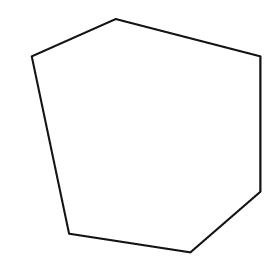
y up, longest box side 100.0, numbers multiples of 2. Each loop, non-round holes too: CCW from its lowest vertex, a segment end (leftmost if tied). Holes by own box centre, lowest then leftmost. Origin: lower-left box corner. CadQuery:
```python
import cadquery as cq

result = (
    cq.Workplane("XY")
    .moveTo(68.0, 0.0)
    .lineTo(98.0, 26.0)
    .lineTo(98.0, 84.0)
    .lineTo(36.0, 100.0)
    .lineTo(0.0, 84.0)
    .lineTo(16.0, 8.0)
    .close()
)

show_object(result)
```